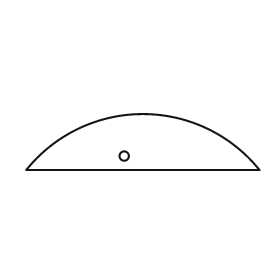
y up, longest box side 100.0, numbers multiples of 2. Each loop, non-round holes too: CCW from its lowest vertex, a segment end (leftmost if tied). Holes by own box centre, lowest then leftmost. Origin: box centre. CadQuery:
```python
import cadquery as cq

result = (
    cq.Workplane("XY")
    .moveTo(-50.0, -12.0)
    .lineTo(50.0, -12.0)
    .threePointArc((0.0, 12.0), (-50.0, -12.0))
    .close()
    .moveTo(-8.0, -6.0)
    .circle(2.0)
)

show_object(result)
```